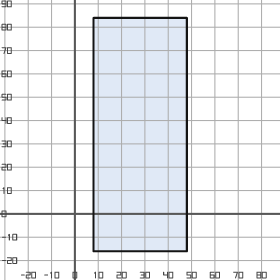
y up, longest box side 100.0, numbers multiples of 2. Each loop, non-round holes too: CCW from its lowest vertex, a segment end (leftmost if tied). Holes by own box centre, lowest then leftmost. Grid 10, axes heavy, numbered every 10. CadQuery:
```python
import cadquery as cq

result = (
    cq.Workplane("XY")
    .moveTo(8.0, -16.0)
    .lineTo(48.0, -16.0)
    .lineTo(48.0, 84.0)
    .lineTo(8.0, 84.0)
    .close()
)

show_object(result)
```